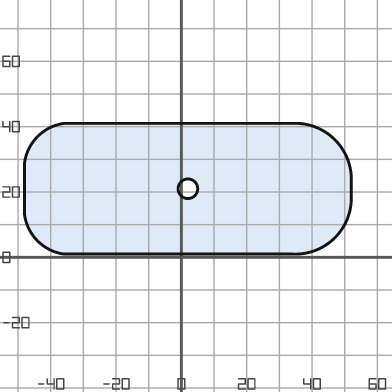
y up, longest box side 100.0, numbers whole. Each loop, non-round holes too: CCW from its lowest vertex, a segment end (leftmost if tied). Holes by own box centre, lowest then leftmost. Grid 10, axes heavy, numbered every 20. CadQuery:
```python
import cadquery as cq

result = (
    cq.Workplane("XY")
    .moveTo(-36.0, 1.0)
    .lineTo(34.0, 1.0)
    .threePointArc((47.0, 6.0), (52.0, 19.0))
    .lineTo(52.0, 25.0)
    .threePointArc((47.0, 36.0), (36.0, 41.0))
    .lineTo(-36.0, 41.0)
    .threePointArc((-44.0, 37.0), (-48.0, 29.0))
    .lineTo(-48.0, 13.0)
    .threePointArc((-44.0, 5.0), (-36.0, 1.0))
    .close()
    .moveTo(2.0, 21.0)
    .circle(3.0)
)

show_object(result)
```